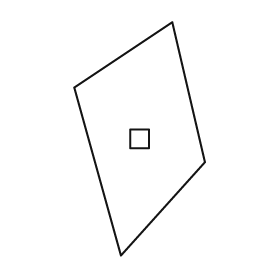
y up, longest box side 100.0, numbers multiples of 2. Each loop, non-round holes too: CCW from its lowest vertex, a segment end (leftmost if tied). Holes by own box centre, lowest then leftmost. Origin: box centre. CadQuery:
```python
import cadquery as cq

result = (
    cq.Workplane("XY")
    .moveTo(-8.0, -50.0)
    .lineTo(28.0, -10.0)
    .lineTo(14.0, 50.0)
    .lineTo(-28.0, 22.0)
    .close()
    .moveTo(-4.0, -4.0)
    .lineTo(4.0, -4.0)
    .lineTo(4.0, 4.0)
    .lineTo(-4.0, 4.0)
    .close()
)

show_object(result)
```